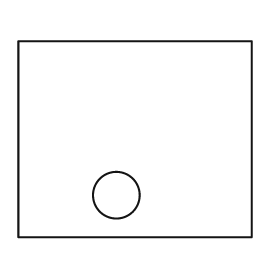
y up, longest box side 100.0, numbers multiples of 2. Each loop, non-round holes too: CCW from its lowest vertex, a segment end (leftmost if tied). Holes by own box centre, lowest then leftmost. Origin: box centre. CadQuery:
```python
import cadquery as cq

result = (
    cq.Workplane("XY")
    .moveTo(-50.0, -42.0)
    .lineTo(50.0, -42.0)
    .lineTo(50.0, 42.0)
    .lineTo(-50.0, 42.0)
    .close()
    .moveTo(-8.0, -24.0)
    .circle(10.0)
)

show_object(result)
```